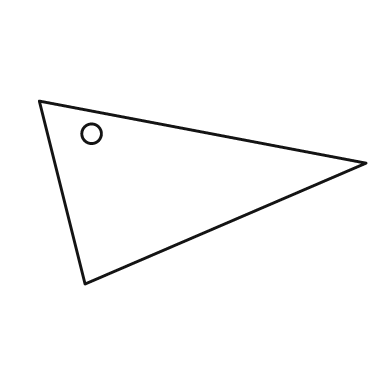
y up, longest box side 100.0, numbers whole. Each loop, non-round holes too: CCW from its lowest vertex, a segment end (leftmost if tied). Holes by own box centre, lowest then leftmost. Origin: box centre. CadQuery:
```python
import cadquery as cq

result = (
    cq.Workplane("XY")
    .moveTo(-36.0, -28.0)
    .lineTo(50.0, 9.0)
    .lineTo(-50.0, 28.0)
    .close()
    .moveTo(-34.0, 18.0)
    .circle(3.0)
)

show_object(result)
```